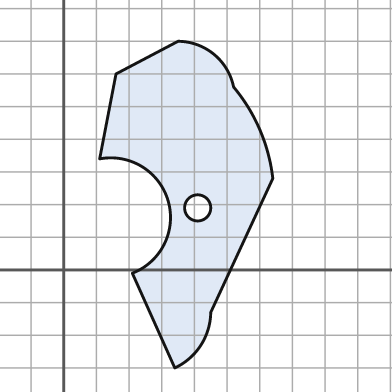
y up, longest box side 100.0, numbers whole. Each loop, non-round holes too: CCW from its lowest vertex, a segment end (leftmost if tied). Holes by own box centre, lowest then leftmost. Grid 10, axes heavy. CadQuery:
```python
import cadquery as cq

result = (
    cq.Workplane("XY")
    .moveTo(34.0, -30.0)
    .threePointArc((42.0, -23.0), (45.0, -13.0))
    .lineTo(64.0, 28.0)
    .threePointArc((60.0, 43.0), (52.0, 56.0))
    .threePointArc((46.0, 66.0), (35.0, 70.0))
    .lineTo(16.0, 60.0)
    .lineTo(11.0, 34.0)
    .threePointArc((32.0, 21.0), (21.0, -1.0))
    .close()
    .moveTo(41.0, 19.0)
    .circle(4.0)
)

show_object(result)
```